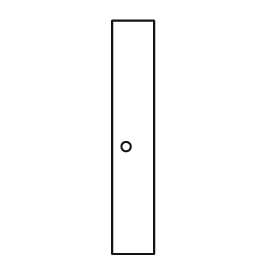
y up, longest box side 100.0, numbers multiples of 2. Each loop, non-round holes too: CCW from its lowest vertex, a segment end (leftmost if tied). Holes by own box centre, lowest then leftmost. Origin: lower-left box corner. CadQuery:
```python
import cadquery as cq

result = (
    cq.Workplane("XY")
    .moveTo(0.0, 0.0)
    .lineTo(18.0, 0.0)
    .lineTo(18.0, 100.0)
    .lineTo(0.0, 100.0)
    .close()
    .moveTo(6.0, 46.0)
    .circle(2.0)
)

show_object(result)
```